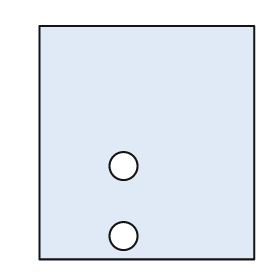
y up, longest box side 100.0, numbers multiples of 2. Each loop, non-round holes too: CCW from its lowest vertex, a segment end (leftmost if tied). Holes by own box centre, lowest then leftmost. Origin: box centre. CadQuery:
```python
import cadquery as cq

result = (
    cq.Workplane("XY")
    .moveTo(-46.0, -50.0)
    .lineTo(46.0, -50.0)
    .lineTo(46.0, 50.0)
    .lineTo(-46.0, 50.0)
    .close()
    .moveTo(-10.0, -40.0)
    .circle(6.0)
    .moveTo(-10.0, -10.0)
    .circle(6.0)
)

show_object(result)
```